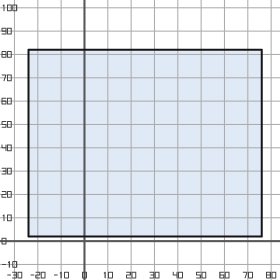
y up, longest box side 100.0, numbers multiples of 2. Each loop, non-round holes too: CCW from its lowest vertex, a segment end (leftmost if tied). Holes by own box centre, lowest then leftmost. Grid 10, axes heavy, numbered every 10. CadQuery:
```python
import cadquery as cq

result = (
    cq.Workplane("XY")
    .moveTo(-24.0, 2.0)
    .lineTo(76.0, 2.0)
    .lineTo(76.0, 82.0)
    .lineTo(-24.0, 82.0)
    .close()
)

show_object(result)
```